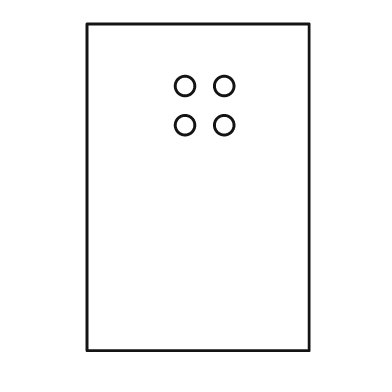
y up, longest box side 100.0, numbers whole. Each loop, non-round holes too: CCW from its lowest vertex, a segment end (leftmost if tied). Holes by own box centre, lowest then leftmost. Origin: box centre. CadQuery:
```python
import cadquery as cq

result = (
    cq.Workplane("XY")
    .moveTo(-34.0, -50.0)
    .lineTo(34.0, -50.0)
    .lineTo(34.0, 50.0)
    .lineTo(-34.0, 50.0)
    .close()
    .moveTo(-4.0, 19.0)
    .circle(3.0)
    .moveTo(8.0, 19.0)
    .circle(3.0)
    .moveTo(-4.0, 31.0)
    .circle(3.0)
    .moveTo(8.0, 31.0)
    .circle(3.0)
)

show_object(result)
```